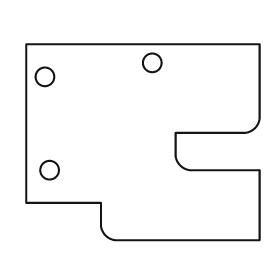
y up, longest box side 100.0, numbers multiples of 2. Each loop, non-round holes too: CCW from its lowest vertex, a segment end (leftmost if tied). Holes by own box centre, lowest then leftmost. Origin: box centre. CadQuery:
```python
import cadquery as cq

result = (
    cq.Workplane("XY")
    .moveTo(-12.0, -42.0)
    .lineTo(50.0, -42.0)
    .lineTo(50.0, -12.0)
    .lineTo(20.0, -12.0)
    .threePointArc((16.0, -10.0), (14.0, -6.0))
    .lineTo(14.0, 4.0)
    .lineTo(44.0, 4.0)
    .threePointArc((48.0, 6.0), (50.0, 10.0))
    .lineTo(50.0, 42.0)
    .lineTo(-50.0, 42.0)
    .lineTo(-50.0, -26.0)
    .lineTo(-18.0, -26.0)
    .lineTo(-18.0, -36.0)
    .threePointArc((-16.0, -40.0), (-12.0, -42.0))
    .close()
    .moveTo(-40.0, -12.0)
    .circle(4.0)
    .moveTo(-42.0, 28.0)
    .circle(4.0)
    .moveTo(4.0, 34.0)
    .circle(4.0)
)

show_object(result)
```